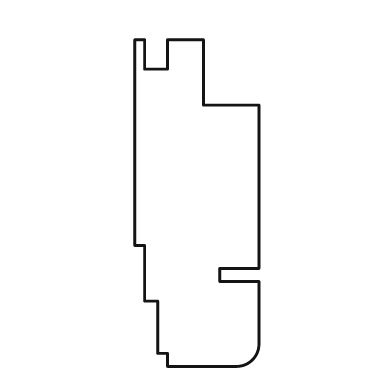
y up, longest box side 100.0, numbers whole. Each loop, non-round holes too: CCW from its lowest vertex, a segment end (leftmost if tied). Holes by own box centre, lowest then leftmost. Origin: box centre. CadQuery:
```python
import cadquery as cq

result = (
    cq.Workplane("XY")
    .moveTo(-9.0, -50.0)
    .lineTo(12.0, -50.0)
    .threePointArc((17.0, -48.0), (19.0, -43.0))
    .lineTo(19.0, -24.0)
    .lineTo(7.0, -24.0)
    .lineTo(7.0, -20.0)
    .lineTo(19.0, -20.0)
    .lineTo(19.0, 30.0)
    .lineTo(2.0, 30.0)
    .lineTo(2.0, 50.0)
    .lineTo(-9.0, 50.0)
    .lineTo(-9.0, 41.0)
    .lineTo(-16.0, 41.0)
    .lineTo(-16.0, 50.0)
    .lineTo(-19.0, 50.0)
    .lineTo(-19.0, -13.0)
    .lineTo(-16.0, -13.0)
    .lineTo(-16.0, -30.0)
    .lineTo(-12.0, -30.0)
    .lineTo(-12.0, -46.0)
    .lineTo(-9.0, -46.0)
    .close()
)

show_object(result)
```